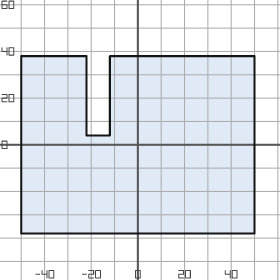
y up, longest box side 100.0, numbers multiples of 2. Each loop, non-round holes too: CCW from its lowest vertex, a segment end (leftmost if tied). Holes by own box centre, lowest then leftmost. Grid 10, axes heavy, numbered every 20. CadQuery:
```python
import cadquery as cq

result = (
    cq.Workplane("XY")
    .moveTo(-50.0, -38.0)
    .lineTo(50.0, -38.0)
    .lineTo(50.0, 38.0)
    .lineTo(-12.0, 38.0)
    .lineTo(-12.0, 4.0)
    .lineTo(-22.0, 4.0)
    .lineTo(-22.0, 38.0)
    .lineTo(-50.0, 38.0)
    .close()
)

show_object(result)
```